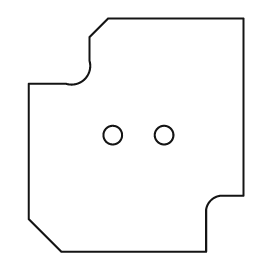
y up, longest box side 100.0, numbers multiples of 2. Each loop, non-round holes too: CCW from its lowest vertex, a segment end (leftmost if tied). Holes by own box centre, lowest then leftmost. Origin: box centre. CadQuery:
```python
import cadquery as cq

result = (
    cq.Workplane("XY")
    .moveTo(-32.0, -50.0)
    .lineTo(30.0, -50.0)
    .lineTo(30.0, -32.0)
    .threePointArc((32.0, -28.0), (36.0, -26.0))
    .lineTo(46.0, -26.0)
    .lineTo(46.0, 50.0)
    .lineTo(-12.0, 50.0)
    .lineTo(-20.0, 42.0)
    .lineTo(-20.0, 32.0)
    .threePointArc((-22.0, 24.0), (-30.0, 22.0))
    .lineTo(-46.0, 22.0)
    .lineTo(-46.0, -36.0)
    .close()
    .moveTo(-10.0, 0.0)
    .circle(4.0)
    .moveTo(12.0, 0.0)
    .circle(4.0)
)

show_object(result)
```